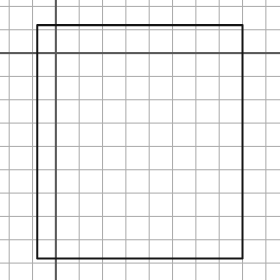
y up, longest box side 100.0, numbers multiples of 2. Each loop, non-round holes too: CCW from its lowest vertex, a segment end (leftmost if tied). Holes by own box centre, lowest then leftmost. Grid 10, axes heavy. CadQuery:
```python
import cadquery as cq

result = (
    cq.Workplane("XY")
    .moveTo(-8.0, -88.0)
    .lineTo(80.0, -88.0)
    .lineTo(80.0, 12.0)
    .lineTo(-8.0, 12.0)
    .close()
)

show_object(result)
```